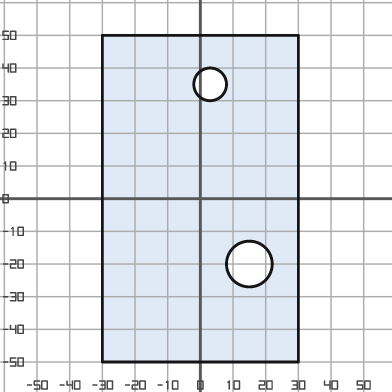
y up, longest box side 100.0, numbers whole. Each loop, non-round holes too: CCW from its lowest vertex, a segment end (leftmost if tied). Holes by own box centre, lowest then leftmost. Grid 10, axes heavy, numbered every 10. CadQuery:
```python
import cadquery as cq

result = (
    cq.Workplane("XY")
    .moveTo(-30.0, -50.0)
    .lineTo(30.0, -50.0)
    .lineTo(30.0, 50.0)
    .lineTo(-30.0, 50.0)
    .close()
    .moveTo(15.0, -20.0)
    .circle(7.0)
    .moveTo(3.0, 35.0)
    .circle(5.0)
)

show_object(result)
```